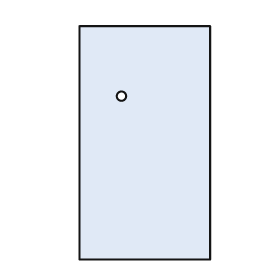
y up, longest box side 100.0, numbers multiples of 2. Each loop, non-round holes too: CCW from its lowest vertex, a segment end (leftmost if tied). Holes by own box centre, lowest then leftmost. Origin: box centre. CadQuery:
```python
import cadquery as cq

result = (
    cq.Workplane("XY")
    .moveTo(-28.0, -50.0)
    .lineTo(28.0, -50.0)
    .lineTo(28.0, 50.0)
    .lineTo(-28.0, 50.0)
    .close()
    .moveTo(-10.0, 20.0)
    .circle(2.0)
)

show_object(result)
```